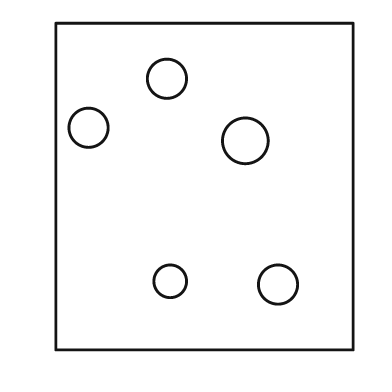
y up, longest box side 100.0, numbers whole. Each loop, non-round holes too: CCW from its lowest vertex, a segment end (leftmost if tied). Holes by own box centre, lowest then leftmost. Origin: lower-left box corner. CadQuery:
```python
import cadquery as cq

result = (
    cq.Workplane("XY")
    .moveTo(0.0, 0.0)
    .lineTo(91.0, 0.0)
    .lineTo(91.0, 100.0)
    .lineTo(0.0, 100.0)
    .close()
    .moveTo(68.0, 20.0)
    .circle(6.0)
    .moveTo(35.0, 21.0)
    .circle(5.0)
    .moveTo(58.0, 64.0)
    .circle(7.0)
    .moveTo(10.0, 68.0)
    .circle(6.0)
    .moveTo(34.0, 83.0)
    .circle(6.0)
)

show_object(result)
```